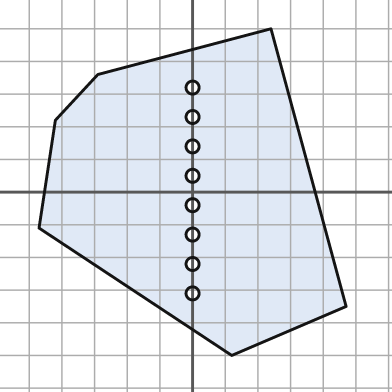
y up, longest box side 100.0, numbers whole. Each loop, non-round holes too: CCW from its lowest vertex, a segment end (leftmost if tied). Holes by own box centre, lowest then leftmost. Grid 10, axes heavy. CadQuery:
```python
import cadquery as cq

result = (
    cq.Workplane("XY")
    .moveTo(12.0, -50.0)
    .lineTo(47.0, -35.0)
    .lineTo(24.0, 50.0)
    .lineTo(-29.0, 36.0)
    .lineTo(-42.0, 22.0)
    .lineTo(-47.0, -11.0)
    .close()
    .moveTo(0.0, -31.0)
    .circle(2.0)
    .moveTo(0.0, -22.0)
    .circle(2.0)
    .moveTo(0.0, -13.0)
    .circle(2.0)
    .moveTo(0.0, -4.0)
    .circle(2.0)
    .moveTo(0.0, 5.0)
    .circle(2.0)
    .moveTo(0.0, 14.0)
    .circle(2.0)
    .moveTo(0.0, 23.0)
    .circle(2.0)
    .moveTo(0.0, 32.0)
    .circle(2.0)
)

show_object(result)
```